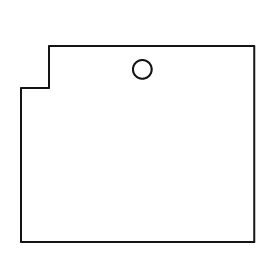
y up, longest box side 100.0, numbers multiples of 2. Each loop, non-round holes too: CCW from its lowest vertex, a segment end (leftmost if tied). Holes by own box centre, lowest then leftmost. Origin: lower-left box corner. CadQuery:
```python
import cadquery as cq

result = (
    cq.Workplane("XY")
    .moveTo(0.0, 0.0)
    .lineTo(100.0, 0.0)
    .lineTo(100.0, 84.0)
    .lineTo(12.0, 84.0)
    .lineTo(12.0, 66.0)
    .lineTo(0.0, 66.0)
    .close()
    .moveTo(52.0, 74.0)
    .circle(4.0)
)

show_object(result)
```